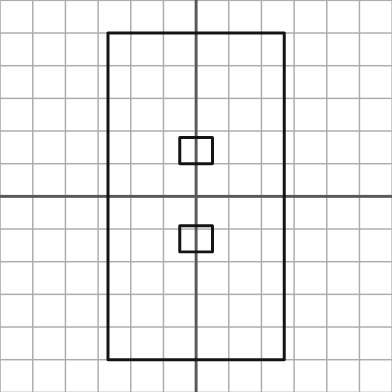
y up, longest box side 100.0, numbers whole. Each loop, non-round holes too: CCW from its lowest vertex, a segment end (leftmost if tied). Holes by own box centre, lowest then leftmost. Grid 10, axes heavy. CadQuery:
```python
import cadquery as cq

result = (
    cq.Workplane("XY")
    .moveTo(-27.0, -50.0)
    .lineTo(27.0, -50.0)
    .lineTo(27.0, 50.0)
    .lineTo(-27.0, 50.0)
    .close()
    .moveTo(-5.0, -17.0)
    .lineTo(5.0, -17.0)
    .lineTo(5.0, -9.0)
    .lineTo(-5.0, -9.0)
    .close()
    .moveTo(-5.0, 10.0)
    .lineTo(5.0, 10.0)
    .lineTo(5.0, 18.0)
    .lineTo(-5.0, 18.0)
    .close()
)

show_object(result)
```